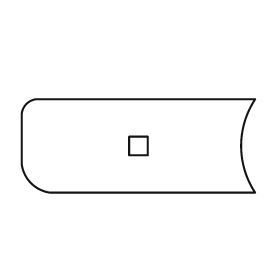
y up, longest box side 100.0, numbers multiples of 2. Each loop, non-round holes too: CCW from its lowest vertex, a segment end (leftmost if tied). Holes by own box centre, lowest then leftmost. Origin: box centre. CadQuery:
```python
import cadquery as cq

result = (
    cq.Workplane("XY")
    .moveTo(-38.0, -20.0)
    .lineTo(50.0, -20.0)
    .threePointArc((44.0, 0.0), (50.0, 20.0))
    .lineTo(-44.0, 20.0)
    .threePointArc((-48.0, 18.0), (-50.0, 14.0))
    .lineTo(-50.0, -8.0)
    .threePointArc((-46.0, -16.0), (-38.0, -20.0))
    .close()
    .moveTo(-4.0, -4.0)
    .lineTo(4.0, -4.0)
    .lineTo(4.0, 4.0)
    .lineTo(-4.0, 4.0)
    .close()
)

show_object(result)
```